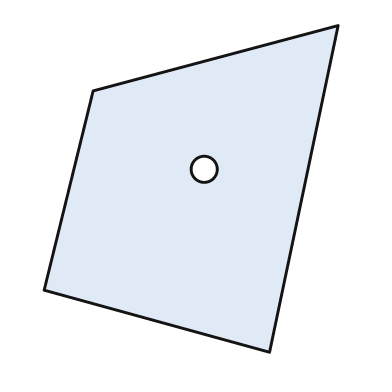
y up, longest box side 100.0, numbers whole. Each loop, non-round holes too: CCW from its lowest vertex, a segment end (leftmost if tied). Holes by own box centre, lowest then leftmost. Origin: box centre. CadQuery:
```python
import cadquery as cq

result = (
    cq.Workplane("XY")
    .moveTo(24.0, -50.0)
    .lineTo(45.0, 50.0)
    .lineTo(-30.0, 30.0)
    .lineTo(-45.0, -31.0)
    .close()
    .moveTo(4.0, 6.0)
    .circle(4.0)
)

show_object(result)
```